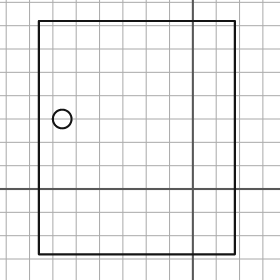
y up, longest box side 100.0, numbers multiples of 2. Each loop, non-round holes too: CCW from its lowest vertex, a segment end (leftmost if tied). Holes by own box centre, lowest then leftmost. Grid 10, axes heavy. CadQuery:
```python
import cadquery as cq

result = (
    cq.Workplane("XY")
    .moveTo(-66.0, -28.0)
    .lineTo(18.0, -28.0)
    .lineTo(18.0, 72.0)
    .lineTo(-66.0, 72.0)
    .close()
    .moveTo(-56.0, 30.0)
    .circle(4.0)
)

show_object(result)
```